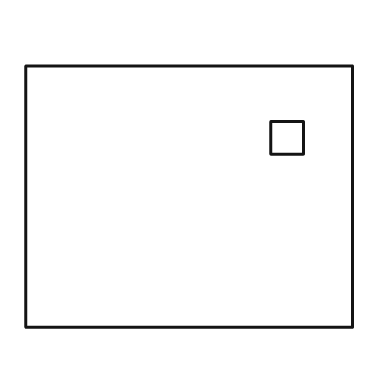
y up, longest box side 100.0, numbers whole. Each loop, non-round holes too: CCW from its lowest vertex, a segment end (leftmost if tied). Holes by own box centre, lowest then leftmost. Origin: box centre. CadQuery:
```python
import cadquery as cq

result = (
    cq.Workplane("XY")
    .moveTo(-50.0, -40.0)
    .lineTo(50.0, -40.0)
    .lineTo(50.0, 40.0)
    .lineTo(-50.0, 40.0)
    .close()
    .moveTo(25.0, 13.0)
    .lineTo(35.0, 13.0)
    .lineTo(35.0, 23.0)
    .lineTo(25.0, 23.0)
    .close()
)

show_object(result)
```